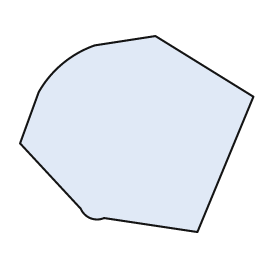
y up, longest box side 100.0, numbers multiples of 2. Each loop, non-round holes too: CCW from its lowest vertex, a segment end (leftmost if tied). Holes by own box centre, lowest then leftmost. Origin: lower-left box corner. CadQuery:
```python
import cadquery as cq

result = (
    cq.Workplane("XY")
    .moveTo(76.0, 0.0)
    .lineTo(100.0, 58.0)
    .lineTo(58.0, 84.0)
    .lineTo(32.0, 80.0)
    .threePointArc((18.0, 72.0), (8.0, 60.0))
    .lineTo(0.0, 38.0)
    .lineTo(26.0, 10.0)
    .threePointArc((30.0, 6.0), (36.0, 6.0))
    .close()
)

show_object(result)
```